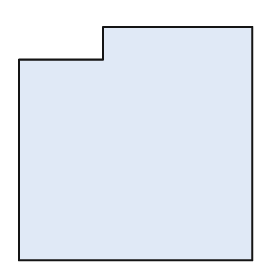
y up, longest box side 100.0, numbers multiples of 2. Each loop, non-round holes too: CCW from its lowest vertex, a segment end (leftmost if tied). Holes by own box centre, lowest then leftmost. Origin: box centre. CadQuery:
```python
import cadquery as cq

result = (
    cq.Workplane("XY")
    .moveTo(-50.0, -50.0)
    .lineTo(50.0, -50.0)
    .lineTo(50.0, 50.0)
    .lineTo(-14.0, 50.0)
    .lineTo(-14.0, 36.0)
    .lineTo(-50.0, 36.0)
    .close()
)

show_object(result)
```